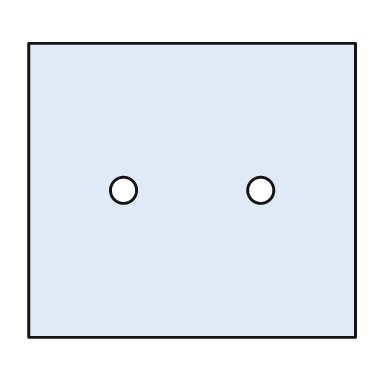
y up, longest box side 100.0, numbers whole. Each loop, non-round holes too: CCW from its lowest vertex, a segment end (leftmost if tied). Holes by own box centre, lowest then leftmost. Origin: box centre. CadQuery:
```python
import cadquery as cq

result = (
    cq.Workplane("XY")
    .moveTo(-50.0, -45.0)
    .lineTo(50.0, -45.0)
    .lineTo(50.0, 45.0)
    .lineTo(-50.0, 45.0)
    .close()
    .moveTo(-21.0, 0.0)
    .circle(4.0)
    .moveTo(21.0, 0.0)
    .circle(4.0)
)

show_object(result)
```